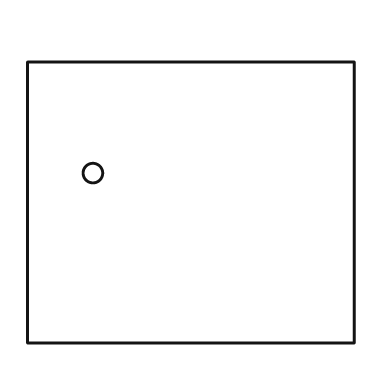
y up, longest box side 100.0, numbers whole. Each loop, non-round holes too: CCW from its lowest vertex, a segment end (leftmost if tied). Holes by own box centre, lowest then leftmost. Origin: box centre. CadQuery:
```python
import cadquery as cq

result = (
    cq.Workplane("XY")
    .moveTo(-50.0, -43.0)
    .lineTo(50.0, -43.0)
    .lineTo(50.0, 43.0)
    .lineTo(-50.0, 43.0)
    .close()
    .moveTo(-30.0, 9.0)
    .circle(3.0)
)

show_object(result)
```